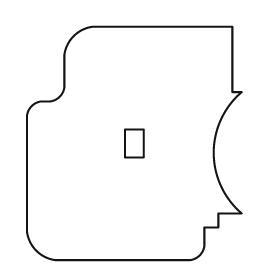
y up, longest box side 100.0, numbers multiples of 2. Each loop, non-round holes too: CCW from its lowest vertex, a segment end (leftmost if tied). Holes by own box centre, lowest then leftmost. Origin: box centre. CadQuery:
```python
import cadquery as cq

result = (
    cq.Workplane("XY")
    .moveTo(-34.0, -50.0)
    .lineTo(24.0, -50.0)
    .threePointArc((28.0, -48.0), (30.0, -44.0))
    .lineTo(30.0, -36.0)
    .lineTo(36.0, -36.0)
    .lineTo(36.0, -30.0)
    .lineTo(46.0, -30.0)
    .threePointArc((34.0, -4.0), (46.0, 22.0))
    .lineTo(42.0, 22.0)
    .lineTo(42.0, 50.0)
    .lineTo(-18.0, 50.0)
    .threePointArc((-26.0, 46.0), (-30.0, 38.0))
    .lineTo(-30.0, 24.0)
    .threePointArc((-32.0, 20.0), (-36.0, 18.0))
    .lineTo(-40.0, 18.0)
    .threePointArc((-44.0, 16.0), (-46.0, 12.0))
    .lineTo(-46.0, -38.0)
    .threePointArc((-42.0, -46.0), (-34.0, -50.0))
    .close()
    .moveTo(-4.0, -6.0)
    .lineTo(4.0, -6.0)
    .lineTo(4.0, 6.0)
    .lineTo(-4.0, 6.0)
    .close()
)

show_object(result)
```